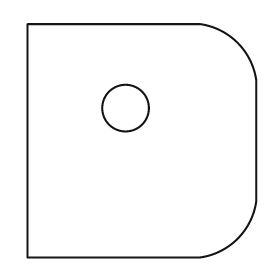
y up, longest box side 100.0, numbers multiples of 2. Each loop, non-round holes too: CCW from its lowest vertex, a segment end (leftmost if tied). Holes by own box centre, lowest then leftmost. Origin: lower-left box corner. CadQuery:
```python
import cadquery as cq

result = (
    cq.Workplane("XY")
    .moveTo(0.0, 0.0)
    .lineTo(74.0, 0.0)
    .threePointArc((90.0, 8.0), (98.0, 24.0))
    .lineTo(98.0, 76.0)
    .threePointArc((90.0, 92.0), (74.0, 100.0))
    .lineTo(0.0, 100.0)
    .close()
    .moveTo(42.0, 64.0)
    .circle(10.0)
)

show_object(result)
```